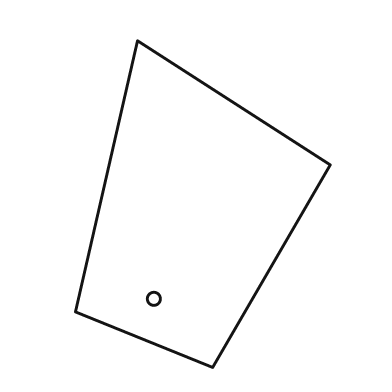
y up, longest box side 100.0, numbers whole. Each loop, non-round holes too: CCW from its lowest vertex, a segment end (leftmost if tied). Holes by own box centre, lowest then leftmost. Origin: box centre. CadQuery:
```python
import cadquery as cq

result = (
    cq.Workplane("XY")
    .moveTo(3.0, -50.0)
    .lineTo(39.0, 12.0)
    .lineTo(-20.0, 50.0)
    .lineTo(-39.0, -33.0)
    .close()
    .moveTo(-15.0, -29.0)
    .circle(2.0)
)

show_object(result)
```